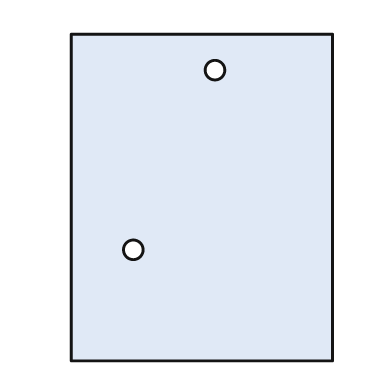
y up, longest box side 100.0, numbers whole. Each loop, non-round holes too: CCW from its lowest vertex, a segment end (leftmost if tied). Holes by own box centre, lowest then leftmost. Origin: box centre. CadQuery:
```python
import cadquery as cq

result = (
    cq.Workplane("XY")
    .moveTo(-40.0, -50.0)
    .lineTo(40.0, -50.0)
    .lineTo(40.0, 50.0)
    .lineTo(-40.0, 50.0)
    .close()
    .moveTo(-21.0, -16.0)
    .circle(3.0)
    .moveTo(4.0, 39.0)
    .circle(3.0)
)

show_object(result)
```